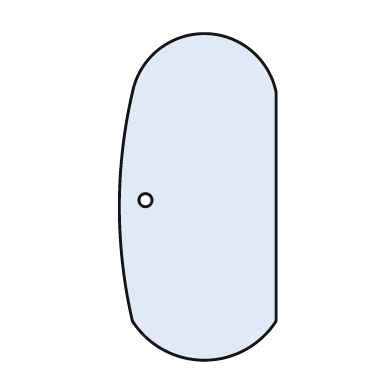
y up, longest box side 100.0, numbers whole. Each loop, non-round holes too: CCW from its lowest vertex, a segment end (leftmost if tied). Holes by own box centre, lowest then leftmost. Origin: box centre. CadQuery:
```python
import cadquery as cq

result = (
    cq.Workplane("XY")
    .moveTo(-20.0, -38.0)
    .threePointArc((2.0, -50.0), (24.0, -38.0))
    .lineTo(24.0, 32.0)
    .threePointArc((2.0, 50.0), (-20.0, 32.0))
    .threePointArc((-24.0, -3.0), (-20.0, -38.0))
    .close()
    .moveTo(-16.0, -1.0)
    .circle(2.0)
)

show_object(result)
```